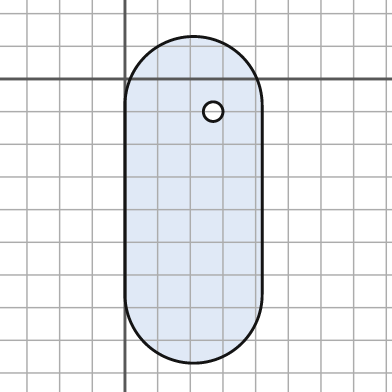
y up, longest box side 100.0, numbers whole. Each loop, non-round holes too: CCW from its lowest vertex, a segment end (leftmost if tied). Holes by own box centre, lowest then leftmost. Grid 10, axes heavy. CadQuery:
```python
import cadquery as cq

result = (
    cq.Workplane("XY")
    .moveTo(0.0, -66.0)
    .threePointArc((21.0, -87.0), (42.0, -66.0))
    .lineTo(42.0, -8.0)
    .threePointArc((21.0, 13.0), (0.0, -8.0))
    .close()
    .moveTo(27.0, -10.0)
    .circle(3.0)
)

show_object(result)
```